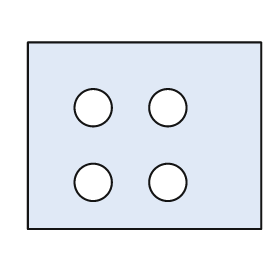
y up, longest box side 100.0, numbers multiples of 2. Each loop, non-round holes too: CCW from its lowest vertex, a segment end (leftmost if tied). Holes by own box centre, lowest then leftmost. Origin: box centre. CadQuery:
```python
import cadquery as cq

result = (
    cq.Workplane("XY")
    .moveTo(-50.0, -40.0)
    .lineTo(50.0, -40.0)
    .lineTo(50.0, 40.0)
    .lineTo(-50.0, 40.0)
    .close()
    .moveTo(-22.0, -20.0)
    .circle(8.0)
    .moveTo(10.0, -20.0)
    .circle(8.0)
    .moveTo(-22.0, 12.0)
    .circle(8.0)
    .moveTo(10.0, 12.0)
    .circle(8.0)
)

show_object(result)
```